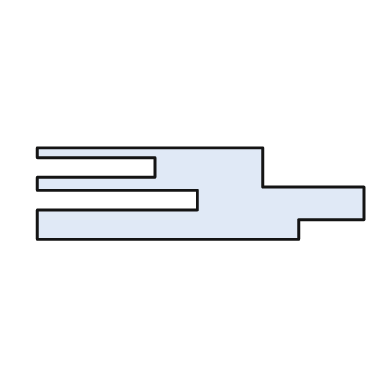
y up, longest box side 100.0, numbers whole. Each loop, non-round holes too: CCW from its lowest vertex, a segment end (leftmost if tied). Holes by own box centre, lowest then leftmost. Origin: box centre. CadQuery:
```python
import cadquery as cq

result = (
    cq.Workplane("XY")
    .moveTo(-50.0, -14.0)
    .lineTo(30.0, -14.0)
    .lineTo(30.0, -8.0)
    .lineTo(50.0, -8.0)
    .lineTo(50.0, 2.0)
    .lineTo(19.0, 2.0)
    .lineTo(19.0, 14.0)
    .lineTo(-50.0, 14.0)
    .lineTo(-50.0, 11.0)
    .lineTo(-14.0, 11.0)
    .lineTo(-14.0, 5.0)
    .lineTo(-50.0, 5.0)
    .lineTo(-50.0, 1.0)
    .lineTo(-1.0, 1.0)
    .lineTo(-1.0, -5.0)
    .lineTo(-50.0, -5.0)
    .close()
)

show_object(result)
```